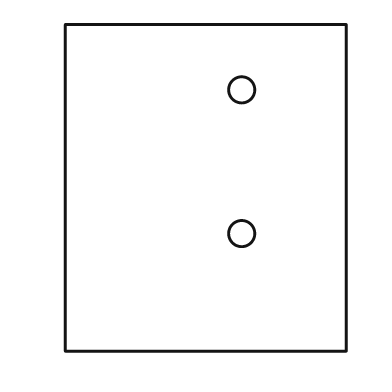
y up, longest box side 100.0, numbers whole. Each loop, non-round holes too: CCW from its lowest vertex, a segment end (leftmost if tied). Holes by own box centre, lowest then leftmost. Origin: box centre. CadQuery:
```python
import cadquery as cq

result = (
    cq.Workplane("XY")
    .moveTo(-43.0, -50.0)
    .lineTo(43.0, -50.0)
    .lineTo(43.0, 50.0)
    .lineTo(-43.0, 50.0)
    .close()
    .moveTo(11.0, -14.0)
    .circle(4.0)
    .moveTo(11.0, 30.0)
    .circle(4.0)
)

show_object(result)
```